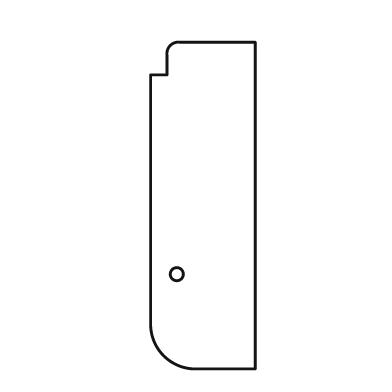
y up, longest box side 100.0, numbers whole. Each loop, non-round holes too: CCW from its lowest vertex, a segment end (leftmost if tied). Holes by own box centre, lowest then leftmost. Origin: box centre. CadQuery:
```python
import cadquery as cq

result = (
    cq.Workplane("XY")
    .moveTo(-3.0, -50.0)
    .lineTo(16.0, -50.0)
    .lineTo(16.0, 50.0)
    .lineTo(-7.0, 50.0)
    .threePointArc((-10.0, 49.0), (-11.0, 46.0))
    .lineTo(-11.0, 40.0)
    .lineTo(-16.0, 40.0)
    .lineTo(-16.0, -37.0)
    .threePointArc((-12.0, -46.0), (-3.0, -50.0))
    .close()
    .moveTo(-8.0, -21.0)
    .circle(2.0)
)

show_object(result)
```